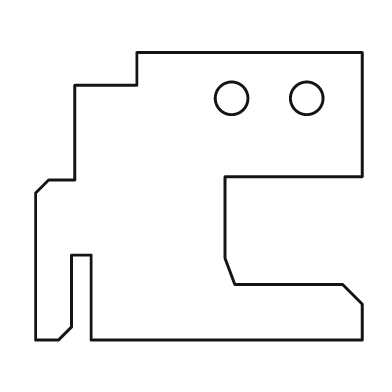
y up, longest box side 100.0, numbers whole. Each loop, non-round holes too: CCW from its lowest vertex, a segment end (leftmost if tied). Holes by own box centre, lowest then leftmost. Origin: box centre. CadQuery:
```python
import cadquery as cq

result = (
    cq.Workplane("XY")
    .moveTo(-50.0, -44.0)
    .lineTo(-43.0, -44.0)
    .lineTo(-39.0, -40.0)
    .lineTo(-39.0, -18.0)
    .lineTo(-33.0, -18.0)
    .lineTo(-33.0, -44.0)
    .lineTo(50.0, -44.0)
    .lineTo(50.0, -33.0)
    .lineTo(44.0, -27.0)
    .lineTo(11.0, -27.0)
    .lineTo(8.0, -19.0)
    .lineTo(8.0, 6.0)
    .lineTo(50.0, 6.0)
    .lineTo(50.0, 44.0)
    .lineTo(-19.0, 44.0)
    .lineTo(-19.0, 34.0)
    .lineTo(-38.0, 34.0)
    .lineTo(-38.0, 5.0)
    .lineTo(-46.0, 5.0)
    .lineTo(-50.0, 1.0)
    .close()
    .moveTo(10.0, 30.0)
    .circle(5.0)
    .moveTo(33.0, 30.0)
    .circle(5.0)
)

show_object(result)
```